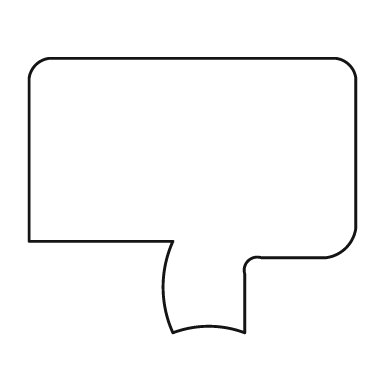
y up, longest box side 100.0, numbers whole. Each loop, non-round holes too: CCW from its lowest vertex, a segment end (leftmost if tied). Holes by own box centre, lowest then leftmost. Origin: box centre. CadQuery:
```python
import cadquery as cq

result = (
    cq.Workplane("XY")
    .moveTo(-6.0, -42.0)
    .threePointArc((5.0, -40.0), (16.0, -42.0))
    .lineTo(16.0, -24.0)
    .threePointArc((17.0, -20.0), (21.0, -19.0))
    .lineTo(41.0, -19.0)
    .threePointArc((47.0, -16.0), (50.0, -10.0))
    .lineTo(50.0, 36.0)
    .threePointArc((48.0, 40.0), (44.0, 42.0))
    .lineTo(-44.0, 42.0)
    .threePointArc((-48.0, 40.0), (-50.0, 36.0))
    .lineTo(-50.0, -14.0)
    .lineTo(-6.0, -14.0)
    .threePointArc((-9.0, -28.0), (-6.0, -42.0))
    .close()
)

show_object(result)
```